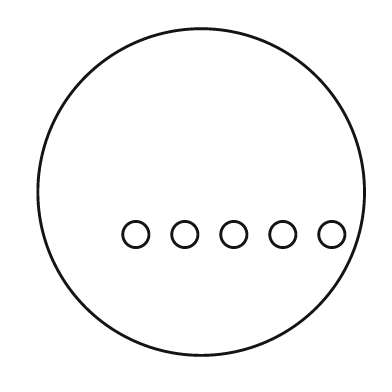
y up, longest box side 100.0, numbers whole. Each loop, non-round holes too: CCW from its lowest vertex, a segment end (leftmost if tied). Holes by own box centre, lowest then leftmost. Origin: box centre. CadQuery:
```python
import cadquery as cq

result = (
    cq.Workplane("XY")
    .moveTo(0.0, 0.0)
    .circle(50.0)
    .moveTo(-20.0, -13.0)
    .circle(4.0)
    .moveTo(-5.0, -13.0)
    .circle(4.0)
    .moveTo(10.0, -13.0)
    .circle(4.0)
    .moveTo(25.0, -13.0)
    .circle(4.0)
    .moveTo(40.0, -13.0)
    .circle(4.0)
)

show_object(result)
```